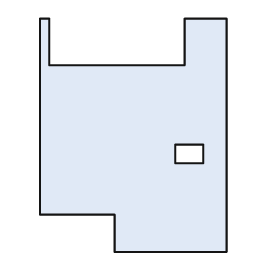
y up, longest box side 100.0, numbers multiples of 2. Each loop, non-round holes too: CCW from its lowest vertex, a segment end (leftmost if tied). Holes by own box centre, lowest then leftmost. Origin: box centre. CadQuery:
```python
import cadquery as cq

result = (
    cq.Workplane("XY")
    .moveTo(-8.0, -50.0)
    .lineTo(40.0, -50.0)
    .lineTo(40.0, 50.0)
    .lineTo(22.0, 50.0)
    .lineTo(22.0, 30.0)
    .lineTo(-36.0, 30.0)
    .lineTo(-36.0, 50.0)
    .lineTo(-40.0, 50.0)
    .lineTo(-40.0, -34.0)
    .lineTo(-8.0, -34.0)
    .close()
    .moveTo(18.0, -12.0)
    .lineTo(30.0, -12.0)
    .lineTo(30.0, -4.0)
    .lineTo(18.0, -4.0)
    .close()
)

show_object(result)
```